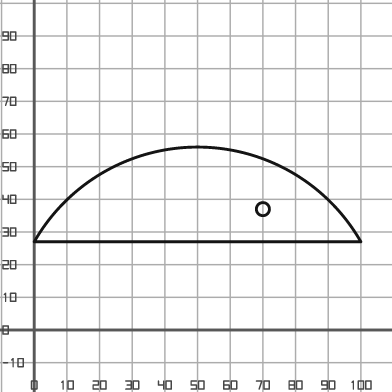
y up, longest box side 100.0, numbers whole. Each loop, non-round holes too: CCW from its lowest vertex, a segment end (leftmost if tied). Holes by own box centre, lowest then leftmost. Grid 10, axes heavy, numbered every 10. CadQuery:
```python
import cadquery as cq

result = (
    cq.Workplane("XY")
    .moveTo(0.0, 27.0)
    .lineTo(100.0, 27.0)
    .threePointArc((50.0, 56.0), (0.0, 27.0))
    .close()
    .moveTo(70.0, 37.0)
    .circle(2.0)
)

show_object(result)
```